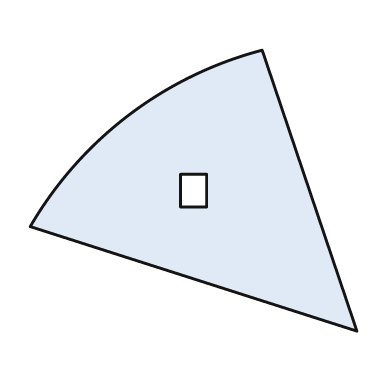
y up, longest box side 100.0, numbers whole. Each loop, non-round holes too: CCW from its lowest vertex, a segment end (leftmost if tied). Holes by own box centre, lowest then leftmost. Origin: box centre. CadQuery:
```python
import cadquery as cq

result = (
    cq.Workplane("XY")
    .moveTo(50.0, -43.0)
    .lineTo(21.0, 43.0)
    .threePointArc((-20.0, 23.0), (-50.0, -11.0))
    .close()
    .moveTo(-4.0, -5.0)
    .lineTo(4.0, -5.0)
    .lineTo(4.0, 5.0)
    .lineTo(-4.0, 5.0)
    .close()
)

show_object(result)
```